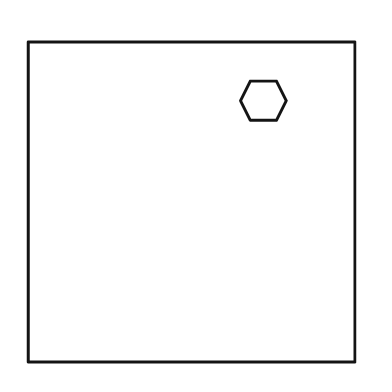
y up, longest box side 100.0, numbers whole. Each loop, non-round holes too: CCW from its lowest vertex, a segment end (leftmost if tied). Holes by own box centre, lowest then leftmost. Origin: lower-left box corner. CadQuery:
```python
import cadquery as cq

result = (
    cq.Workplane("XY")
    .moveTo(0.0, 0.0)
    .lineTo(100.0, 0.0)
    .lineTo(100.0, 98.0)
    .lineTo(0.0, 98.0)
    .close()
    .moveTo(68.0, 74.0)
    .lineTo(76.0, 74.0)
    .lineTo(79.0, 80.0)
    .lineTo(76.0, 86.0)
    .lineTo(68.0, 86.0)
    .lineTo(65.0, 80.0)
    .close()
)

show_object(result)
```